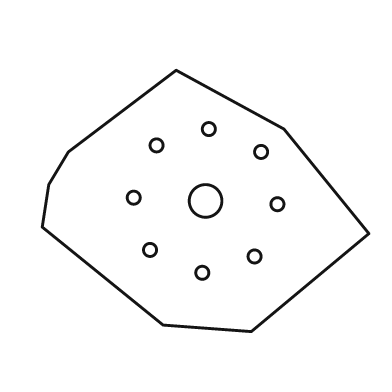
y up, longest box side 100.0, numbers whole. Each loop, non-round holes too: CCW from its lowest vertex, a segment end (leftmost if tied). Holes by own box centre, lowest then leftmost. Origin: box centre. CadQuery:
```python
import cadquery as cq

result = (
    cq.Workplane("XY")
    .moveTo(14.0, -40.0)
    .lineTo(50.0, -10.0)
    .lineTo(24.0, 22.0)
    .lineTo(-9.0, 40.0)
    .lineTo(-42.0, 15.0)
    .lineTo(-48.0, 5.0)
    .lineTo(-50.0, -8.0)
    .lineTo(-13.0, -38.0)
    .close()
    .moveTo(-1.0, -22.0)
    .circle(2.0)
    .moveTo(15.0, -17.0)
    .circle(2.0)
    .moveTo(-17.0, -15.0)
    .circle(2.0)
    .moveTo(22.0, -1.0)
    .circle(2.0)
    .moveTo(0.0, 0.0)
    .circle(5.0)
    .moveTo(-22.0, 1.0)
    .circle(2.0)
    .moveTo(17.0, 15.0)
    .circle(2.0)
    .moveTo(-15.0, 17.0)
    .circle(2.0)
    .moveTo(1.0, 22.0)
    .circle(2.0)
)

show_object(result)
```